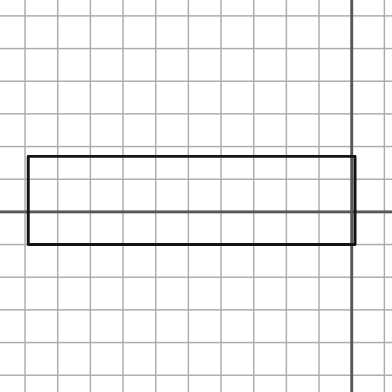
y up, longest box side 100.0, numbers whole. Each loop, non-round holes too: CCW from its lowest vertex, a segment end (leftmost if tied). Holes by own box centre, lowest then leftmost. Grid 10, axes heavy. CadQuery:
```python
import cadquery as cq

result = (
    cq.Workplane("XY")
    .moveTo(-99.0, -10.0)
    .lineTo(1.0, -10.0)
    .lineTo(1.0, 17.0)
    .lineTo(-99.0, 17.0)
    .close()
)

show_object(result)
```